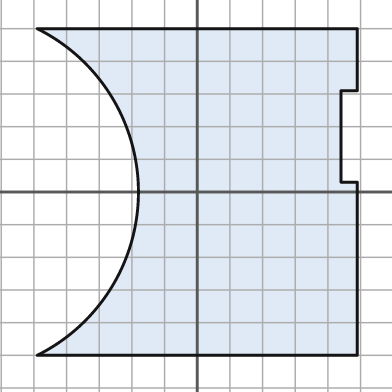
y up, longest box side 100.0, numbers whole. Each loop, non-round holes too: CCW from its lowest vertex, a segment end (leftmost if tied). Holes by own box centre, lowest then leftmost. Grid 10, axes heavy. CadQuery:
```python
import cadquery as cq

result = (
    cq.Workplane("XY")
    .moveTo(-49.0, -50.0)
    .lineTo(49.0, -50.0)
    .lineTo(49.0, 3.0)
    .lineTo(44.0, 3.0)
    .lineTo(44.0, 31.0)
    .lineTo(49.0, 31.0)
    .lineTo(49.0, 50.0)
    .lineTo(-49.0, 50.0)
    .threePointArc((-18.0, 0.0), (-49.0, -50.0))
    .close()
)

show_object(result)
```